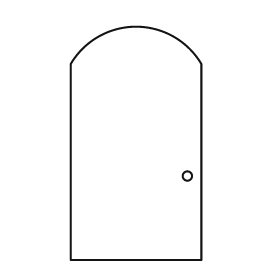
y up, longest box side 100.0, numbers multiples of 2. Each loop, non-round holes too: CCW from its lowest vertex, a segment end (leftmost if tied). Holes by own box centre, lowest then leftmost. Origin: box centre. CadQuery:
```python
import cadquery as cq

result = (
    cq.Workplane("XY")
    .moveTo(-28.0, -50.0)
    .lineTo(28.0, -50.0)
    .lineTo(28.0, 34.0)
    .threePointArc((0.0, 50.0), (-28.0, 34.0))
    .close()
    .moveTo(22.0, -14.0)
    .circle(2.0)
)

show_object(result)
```